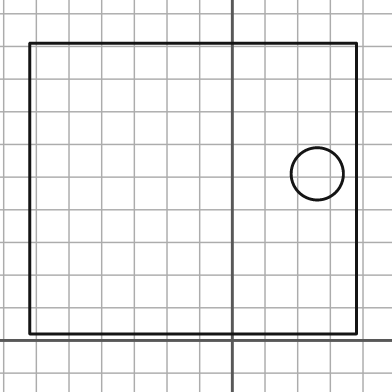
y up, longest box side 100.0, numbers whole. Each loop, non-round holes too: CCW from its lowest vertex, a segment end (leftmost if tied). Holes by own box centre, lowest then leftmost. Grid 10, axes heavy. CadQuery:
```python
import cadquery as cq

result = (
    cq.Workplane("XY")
    .moveTo(-62.0, 2.0)
    .lineTo(38.0, 2.0)
    .lineTo(38.0, 91.0)
    .lineTo(-62.0, 91.0)
    .close()
    .moveTo(26.0, 51.0)
    .circle(8.0)
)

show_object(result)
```